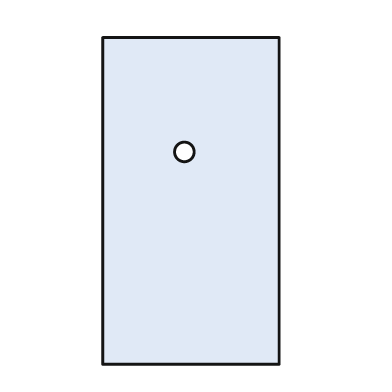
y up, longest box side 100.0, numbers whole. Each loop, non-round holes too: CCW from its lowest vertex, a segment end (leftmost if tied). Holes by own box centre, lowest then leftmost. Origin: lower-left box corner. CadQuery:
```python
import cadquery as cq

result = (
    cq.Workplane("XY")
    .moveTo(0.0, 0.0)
    .lineTo(54.0, 0.0)
    .lineTo(54.0, 100.0)
    .lineTo(0.0, 100.0)
    .close()
    .moveTo(25.0, 65.0)
    .circle(3.0)
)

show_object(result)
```